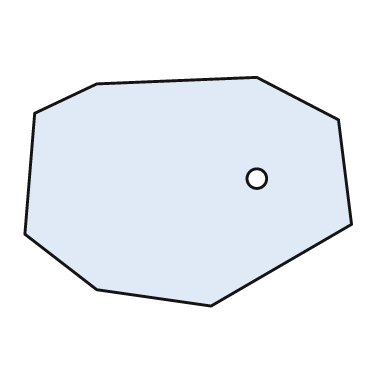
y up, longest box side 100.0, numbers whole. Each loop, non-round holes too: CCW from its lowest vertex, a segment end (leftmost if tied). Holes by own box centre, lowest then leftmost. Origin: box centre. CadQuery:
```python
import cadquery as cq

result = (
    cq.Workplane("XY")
    .moveTo(7.0, -35.0)
    .lineTo(50.0, -10.0)
    .lineTo(46.0, 22.0)
    .lineTo(21.0, 35.0)
    .lineTo(-28.0, 33.0)
    .lineTo(-47.0, 24.0)
    .lineTo(-50.0, -13.0)
    .lineTo(-28.0, -30.0)
    .close()
    .moveTo(21.0, 4.0)
    .circle(3.0)
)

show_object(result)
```